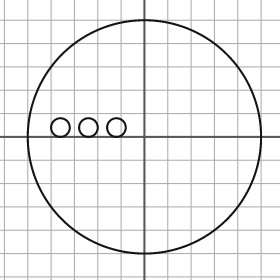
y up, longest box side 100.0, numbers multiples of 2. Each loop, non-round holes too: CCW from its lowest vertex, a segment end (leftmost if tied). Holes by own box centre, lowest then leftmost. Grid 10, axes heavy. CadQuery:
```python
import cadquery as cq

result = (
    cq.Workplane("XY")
    .moveTo(0.0, 0.0)
    .circle(50.0)
    .moveTo(-36.0, 4.0)
    .circle(4.0)
    .moveTo(-24.0, 4.0)
    .circle(4.0)
    .moveTo(-12.0, 4.0)
    .circle(4.0)
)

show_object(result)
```